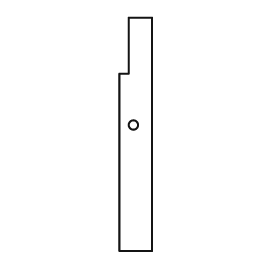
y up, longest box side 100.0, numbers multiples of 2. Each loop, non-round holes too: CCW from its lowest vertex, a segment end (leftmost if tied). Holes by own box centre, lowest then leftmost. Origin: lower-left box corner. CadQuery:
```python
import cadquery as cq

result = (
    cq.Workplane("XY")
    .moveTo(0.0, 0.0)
    .lineTo(14.0, 0.0)
    .lineTo(14.0, 100.0)
    .lineTo(4.0, 100.0)
    .lineTo(4.0, 76.0)
    .lineTo(0.0, 76.0)
    .close()
    .moveTo(6.0, 54.0)
    .circle(2.0)
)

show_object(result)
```